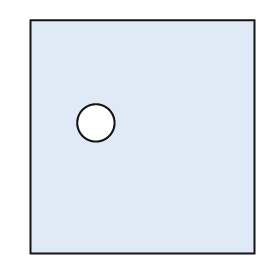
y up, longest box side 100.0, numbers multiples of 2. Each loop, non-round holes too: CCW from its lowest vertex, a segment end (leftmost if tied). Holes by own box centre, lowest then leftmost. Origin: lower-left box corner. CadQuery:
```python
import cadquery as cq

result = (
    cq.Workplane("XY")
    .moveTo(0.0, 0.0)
    .lineTo(96.0, 0.0)
    .lineTo(96.0, 100.0)
    .lineTo(0.0, 100.0)
    .close()
    .moveTo(28.0, 56.0)
    .circle(8.0)
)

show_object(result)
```